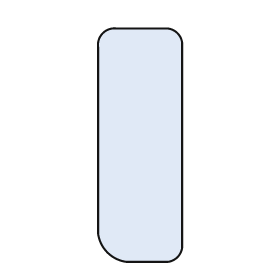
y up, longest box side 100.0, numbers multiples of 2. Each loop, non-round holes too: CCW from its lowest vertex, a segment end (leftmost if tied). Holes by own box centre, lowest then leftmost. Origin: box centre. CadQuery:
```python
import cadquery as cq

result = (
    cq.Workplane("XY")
    .moveTo(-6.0, -50.0)
    .lineTo(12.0, -50.0)
    .threePointArc((16.0, -48.0), (18.0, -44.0))
    .lineTo(18.0, 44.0)
    .threePointArc((16.0, 48.0), (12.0, 50.0))
    .lineTo(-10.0, 50.0)
    .threePointArc((-16.0, 48.0), (-18.0, 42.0))
    .lineTo(-18.0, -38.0)
    .threePointArc((-14.0, -46.0), (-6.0, -50.0))
    .close()
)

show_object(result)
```